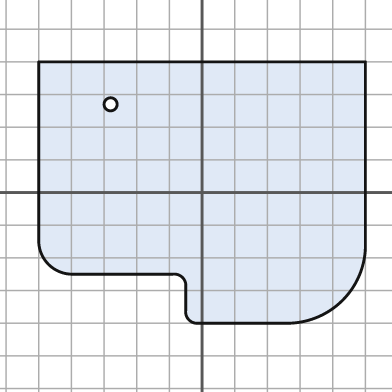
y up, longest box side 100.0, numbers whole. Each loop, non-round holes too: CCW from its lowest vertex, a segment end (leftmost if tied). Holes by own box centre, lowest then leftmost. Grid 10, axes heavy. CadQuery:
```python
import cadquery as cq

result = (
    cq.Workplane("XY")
    .moveTo(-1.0, -40.0)
    .lineTo(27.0, -40.0)
    .threePointArc((43.0, -33.0), (50.0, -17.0))
    .lineTo(50.0, 40.0)
    .lineTo(-50.0, 40.0)
    .lineTo(-50.0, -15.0)
    .threePointArc((-47.0, -22.0), (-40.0, -25.0))
    .lineTo(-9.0, -25.0)
    .threePointArc((-6.0, -26.0), (-5.0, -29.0))
    .lineTo(-5.0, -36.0)
    .threePointArc((-4.0, -39.0), (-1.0, -40.0))
    .close()
    .moveTo(-28.0, 27.0)
    .circle(2.0)
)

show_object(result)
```